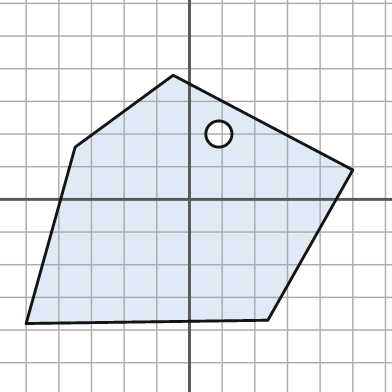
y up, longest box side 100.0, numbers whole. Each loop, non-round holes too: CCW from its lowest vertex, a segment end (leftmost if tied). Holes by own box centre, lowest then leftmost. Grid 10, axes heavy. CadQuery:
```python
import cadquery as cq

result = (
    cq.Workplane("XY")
    .moveTo(-50.0, -38.0)
    .lineTo(24.0, -37.0)
    .lineTo(50.0, 9.0)
    .lineTo(-5.0, 38.0)
    .lineTo(-35.0, 16.0)
    .close()
    .moveTo(9.0, 20.0)
    .circle(4.0)
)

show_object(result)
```